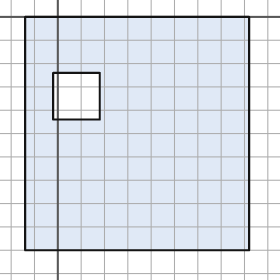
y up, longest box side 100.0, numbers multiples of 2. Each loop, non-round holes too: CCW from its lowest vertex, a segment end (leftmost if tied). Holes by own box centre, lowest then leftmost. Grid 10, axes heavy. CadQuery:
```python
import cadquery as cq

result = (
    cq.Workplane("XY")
    .moveTo(-14.0, -100.0)
    .lineTo(82.0, -100.0)
    .lineTo(82.0, 0.0)
    .lineTo(-14.0, 0.0)
    .close()
    .moveTo(-2.0, -44.0)
    .lineTo(18.0, -44.0)
    .lineTo(18.0, -24.0)
    .lineTo(-2.0, -24.0)
    .close()
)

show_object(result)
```